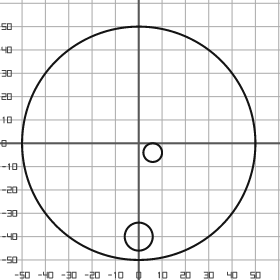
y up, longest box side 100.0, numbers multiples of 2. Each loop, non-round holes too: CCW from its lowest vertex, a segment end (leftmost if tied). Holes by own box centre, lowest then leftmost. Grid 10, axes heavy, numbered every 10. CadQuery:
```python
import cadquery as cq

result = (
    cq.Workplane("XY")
    .moveTo(0.0, 0.0)
    .circle(50.0)
    .moveTo(0.0, -40.0)
    .circle(6.0)
    .moveTo(6.0, -4.0)
    .circle(4.0)
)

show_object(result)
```